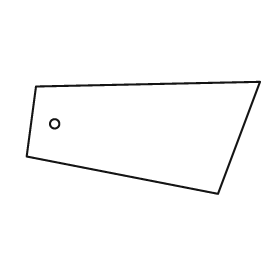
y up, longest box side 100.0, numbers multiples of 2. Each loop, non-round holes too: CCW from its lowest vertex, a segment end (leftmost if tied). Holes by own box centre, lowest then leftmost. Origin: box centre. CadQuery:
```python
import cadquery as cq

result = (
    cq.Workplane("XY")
    .moveTo(32.0, -24.0)
    .lineTo(50.0, 24.0)
    .lineTo(-46.0, 22.0)
    .lineTo(-50.0, -8.0)
    .close()
    .moveTo(-38.0, 6.0)
    .circle(2.0)
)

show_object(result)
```